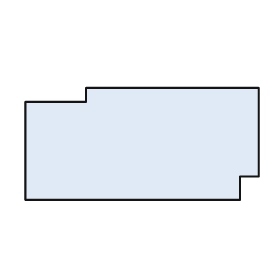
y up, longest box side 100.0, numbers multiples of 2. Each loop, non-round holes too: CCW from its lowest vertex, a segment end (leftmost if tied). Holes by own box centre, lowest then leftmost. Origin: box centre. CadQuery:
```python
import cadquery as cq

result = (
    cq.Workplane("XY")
    .moveTo(-50.0, -24.0)
    .lineTo(42.0, -24.0)
    .lineTo(42.0, -14.0)
    .lineTo(50.0, -14.0)
    .lineTo(50.0, 24.0)
    .lineTo(-24.0, 24.0)
    .lineTo(-24.0, 18.0)
    .lineTo(-50.0, 18.0)
    .close()
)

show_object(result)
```